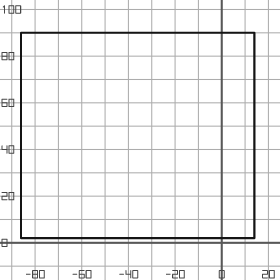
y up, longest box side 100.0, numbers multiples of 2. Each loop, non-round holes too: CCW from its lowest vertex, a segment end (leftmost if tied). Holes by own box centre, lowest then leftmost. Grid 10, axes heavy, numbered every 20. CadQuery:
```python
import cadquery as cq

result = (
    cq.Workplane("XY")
    .moveTo(-86.0, 2.0)
    .lineTo(14.0, 2.0)
    .lineTo(14.0, 90.0)
    .lineTo(-86.0, 90.0)
    .close()
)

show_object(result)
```